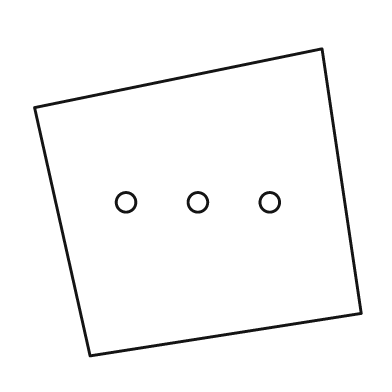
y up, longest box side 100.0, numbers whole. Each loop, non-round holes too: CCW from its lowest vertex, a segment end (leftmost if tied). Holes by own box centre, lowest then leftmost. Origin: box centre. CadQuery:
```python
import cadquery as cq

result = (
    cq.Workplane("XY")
    .moveTo(-33.0, -47.0)
    .lineTo(50.0, -34.0)
    .lineTo(38.0, 47.0)
    .lineTo(-50.0, 29.0)
    .close()
    .moveTo(-22.0, 0.0)
    .circle(3.0)
    .moveTo(0.0, 0.0)
    .circle(3.0)
    .moveTo(22.0, 0.0)
    .circle(3.0)
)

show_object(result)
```